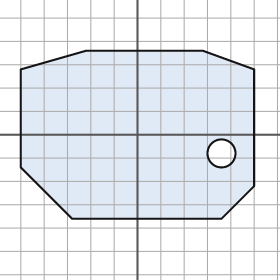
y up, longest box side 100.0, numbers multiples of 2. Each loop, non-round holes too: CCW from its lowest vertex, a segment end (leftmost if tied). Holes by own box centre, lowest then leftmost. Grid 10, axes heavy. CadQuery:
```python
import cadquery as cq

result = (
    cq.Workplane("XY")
    .moveTo(-28.0, -36.0)
    .lineTo(36.0, -36.0)
    .lineTo(50.0, -22.0)
    .lineTo(50.0, 28.0)
    .lineTo(28.0, 36.0)
    .lineTo(-22.0, 36.0)
    .lineTo(-50.0, 28.0)
    .lineTo(-50.0, -14.0)
    .close()
    .moveTo(36.0, -8.0)
    .circle(6.0)
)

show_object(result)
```